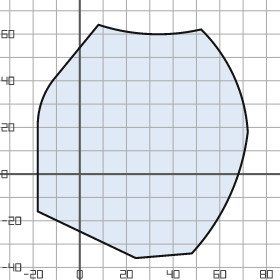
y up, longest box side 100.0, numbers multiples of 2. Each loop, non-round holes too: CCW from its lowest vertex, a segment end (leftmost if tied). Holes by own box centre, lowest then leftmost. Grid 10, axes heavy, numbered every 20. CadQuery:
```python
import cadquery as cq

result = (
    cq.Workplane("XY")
    .moveTo(24.0, -36.0)
    .lineTo(48.0, -34.0)
    .threePointArc((64.0, -10.0), (72.0, 18.0))
    .threePointArc((66.0, 42.0), (52.0, 62.0))
    .threePointArc((30.0, 60.0), (8.0, 64.0))
    .lineTo(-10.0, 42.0)
    .threePointArc((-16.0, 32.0), (-18.0, 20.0))
    .lineTo(-18.0, -16.0)
    .close()
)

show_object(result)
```